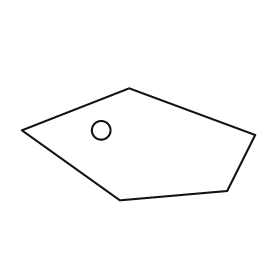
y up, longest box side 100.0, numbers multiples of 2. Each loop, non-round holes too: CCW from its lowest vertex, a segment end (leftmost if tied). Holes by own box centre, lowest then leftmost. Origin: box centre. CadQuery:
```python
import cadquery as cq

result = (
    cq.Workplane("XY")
    .moveTo(-8.0, -24.0)
    .lineTo(38.0, -20.0)
    .lineTo(50.0, 4.0)
    .lineTo(-4.0, 24.0)
    .lineTo(-50.0, 6.0)
    .close()
    .moveTo(-16.0, 6.0)
    .circle(4.0)
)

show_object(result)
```